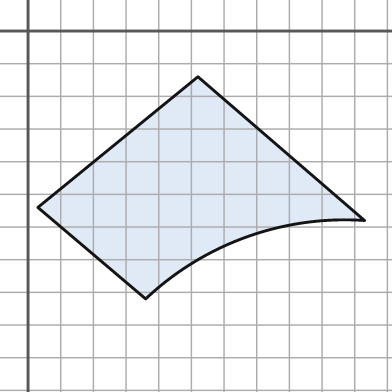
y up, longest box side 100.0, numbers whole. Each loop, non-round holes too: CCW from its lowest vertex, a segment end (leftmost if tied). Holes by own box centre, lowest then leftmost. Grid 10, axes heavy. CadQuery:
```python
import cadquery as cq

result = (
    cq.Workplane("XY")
    .moveTo(36.0, -82.0)
    .threePointArc((67.0, -63.0), (103.0, -58.0))
    .lineTo(52.0, -14.0)
    .lineTo(3.0, -54.0)
    .close()
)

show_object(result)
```